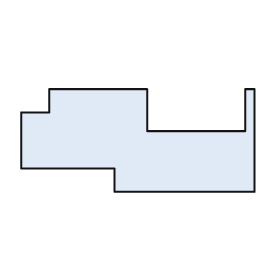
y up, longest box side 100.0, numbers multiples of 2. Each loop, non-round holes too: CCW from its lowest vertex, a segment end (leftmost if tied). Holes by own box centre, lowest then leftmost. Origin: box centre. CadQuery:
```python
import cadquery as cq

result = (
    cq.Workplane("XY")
    .moveTo(-10.0, -22.0)
    .lineTo(50.0, -22.0)
    .lineTo(50.0, 22.0)
    .lineTo(46.0, 22.0)
    .lineTo(46.0, 4.0)
    .lineTo(4.0, 4.0)
    .lineTo(4.0, 22.0)
    .lineTo(-38.0, 22.0)
    .lineTo(-38.0, 12.0)
    .lineTo(-50.0, 12.0)
    .lineTo(-50.0, -12.0)
    .lineTo(-10.0, -12.0)
    .close()
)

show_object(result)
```